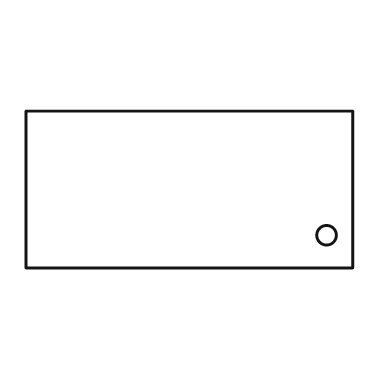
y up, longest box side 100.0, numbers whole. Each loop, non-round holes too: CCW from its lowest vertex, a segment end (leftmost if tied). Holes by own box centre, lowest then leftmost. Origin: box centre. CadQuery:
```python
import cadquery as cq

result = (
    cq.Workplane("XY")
    .moveTo(-50.0, -24.0)
    .lineTo(50.0, -24.0)
    .lineTo(50.0, 24.0)
    .lineTo(-50.0, 24.0)
    .close()
    .moveTo(42.0, -14.0)
    .circle(3.0)
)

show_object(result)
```